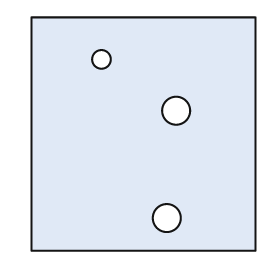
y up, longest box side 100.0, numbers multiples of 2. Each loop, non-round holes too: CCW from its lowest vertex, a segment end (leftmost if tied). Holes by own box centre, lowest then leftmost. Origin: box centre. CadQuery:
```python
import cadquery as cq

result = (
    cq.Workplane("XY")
    .moveTo(-48.0, -50.0)
    .lineTo(48.0, -50.0)
    .lineTo(48.0, 50.0)
    .lineTo(-48.0, 50.0)
    .close()
    .moveTo(10.0, -36.0)
    .circle(6.0)
    .moveTo(14.0, 10.0)
    .circle(6.0)
    .moveTo(-18.0, 32.0)
    .circle(4.0)
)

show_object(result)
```